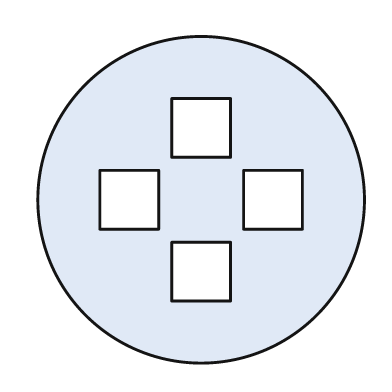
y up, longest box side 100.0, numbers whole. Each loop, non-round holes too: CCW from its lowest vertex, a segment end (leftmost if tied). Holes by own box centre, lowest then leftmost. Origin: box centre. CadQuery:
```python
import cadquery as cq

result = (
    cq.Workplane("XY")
    .moveTo(0.0, 0.0)
    .circle(50.0)
    .moveTo(-9.0, -31.0)
    .lineTo(9.0, -31.0)
    .lineTo(9.0, -13.0)
    .lineTo(-9.0, -13.0)
    .close()
    .moveTo(-31.0, -9.0)
    .lineTo(-13.0, -9.0)
    .lineTo(-13.0, 9.0)
    .lineTo(-31.0, 9.0)
    .close()
    .moveTo(13.0, -9.0)
    .lineTo(31.0, -9.0)
    .lineTo(31.0, 9.0)
    .lineTo(13.0, 9.0)
    .close()
    .moveTo(-9.0, 13.0)
    .lineTo(9.0, 13.0)
    .lineTo(9.0, 31.0)
    .lineTo(-9.0, 31.0)
    .close()
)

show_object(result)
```